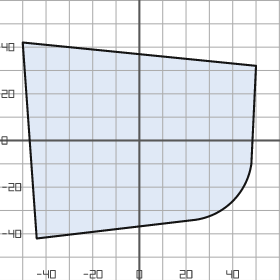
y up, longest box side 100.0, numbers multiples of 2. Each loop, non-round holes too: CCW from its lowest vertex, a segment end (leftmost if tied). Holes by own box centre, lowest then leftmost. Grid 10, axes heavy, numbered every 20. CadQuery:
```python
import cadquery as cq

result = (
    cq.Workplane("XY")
    .moveTo(-44.0, -42.0)
    .lineTo(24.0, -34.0)
    .threePointArc((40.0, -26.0), (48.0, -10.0))
    .lineTo(50.0, 32.0)
    .lineTo(-50.0, 42.0)
    .close()
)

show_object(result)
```